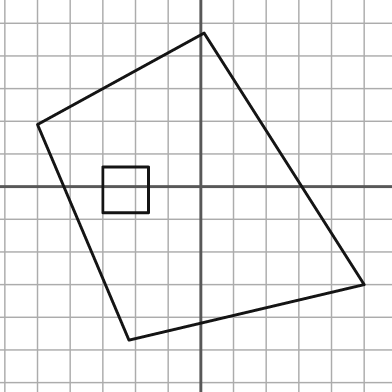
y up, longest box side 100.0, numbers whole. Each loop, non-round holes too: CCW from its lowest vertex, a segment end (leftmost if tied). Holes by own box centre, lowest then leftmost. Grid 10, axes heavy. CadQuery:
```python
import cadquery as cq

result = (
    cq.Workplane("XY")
    .moveTo(-22.0, -47.0)
    .lineTo(50.0, -30.0)
    .lineTo(1.0, 47.0)
    .lineTo(-50.0, 19.0)
    .close()
    .moveTo(-30.0, -8.0)
    .lineTo(-16.0, -8.0)
    .lineTo(-16.0, 6.0)
    .lineTo(-30.0, 6.0)
    .close()
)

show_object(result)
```